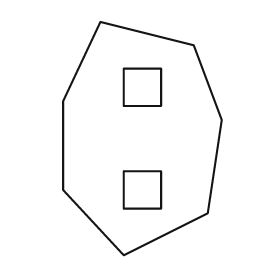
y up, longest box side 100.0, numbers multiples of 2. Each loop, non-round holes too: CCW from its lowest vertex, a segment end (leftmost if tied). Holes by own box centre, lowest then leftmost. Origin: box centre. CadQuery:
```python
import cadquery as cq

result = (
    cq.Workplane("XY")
    .moveTo(-8.0, -50.0)
    .lineTo(28.0, -32.0)
    .lineTo(34.0, 8.0)
    .lineTo(22.0, 40.0)
    .lineTo(-18.0, 50.0)
    .lineTo(-34.0, 16.0)
    .lineTo(-34.0, -22.0)
    .close()
    .moveTo(-8.0, -30.0)
    .lineTo(8.0, -30.0)
    .lineTo(8.0, -14.0)
    .lineTo(-8.0, -14.0)
    .close()
    .moveTo(-8.0, 14.0)
    .lineTo(8.0, 14.0)
    .lineTo(8.0, 30.0)
    .lineTo(-8.0, 30.0)
    .close()
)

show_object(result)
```